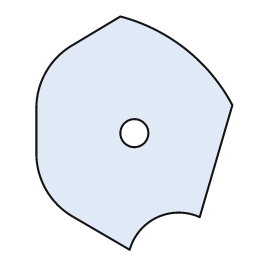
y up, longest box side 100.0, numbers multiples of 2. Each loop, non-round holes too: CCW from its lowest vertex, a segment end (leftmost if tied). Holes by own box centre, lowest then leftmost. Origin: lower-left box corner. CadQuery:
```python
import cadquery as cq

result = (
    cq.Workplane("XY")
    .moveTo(40.0, 0.0)
    .threePointArc((52.0, 14.0), (70.0, 14.0))
    .lineTo(84.0, 62.0)
    .threePointArc((64.0, 86.0), (36.0, 100.0))
    .lineTo(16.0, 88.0)
    .threePointArc((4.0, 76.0), (0.0, 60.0))
    .lineTo(0.0, 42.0)
    .threePointArc((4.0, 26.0), (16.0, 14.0))
    .close()
    .moveTo(42.0, 50.0)
    .circle(6.0)
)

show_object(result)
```